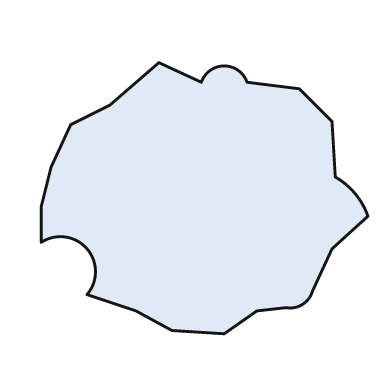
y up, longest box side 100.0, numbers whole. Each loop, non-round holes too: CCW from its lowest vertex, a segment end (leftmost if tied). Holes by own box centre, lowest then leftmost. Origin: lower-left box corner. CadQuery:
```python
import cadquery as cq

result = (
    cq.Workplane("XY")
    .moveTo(56.0, 0.0)
    .lineTo(66.0, 7.0)
    .lineTo(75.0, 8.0)
    .threePointArc((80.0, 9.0), (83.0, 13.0))
    .lineTo(89.0, 26.0)
    .lineTo(100.0, 36.0)
    .threePointArc((96.0, 43.0), (90.0, 48.0))
    .lineTo(89.0, 65.0)
    .lineTo(79.0, 75.0)
    .lineTo(63.0, 77.0)
    .threePointArc((56.0, 82.0), (49.0, 77.0))
    .lineTo(36.0, 83.0)
    .lineTo(21.0, 70.0)
    .lineTo(9.0, 64.0)
    .lineTo(3.0, 51.0)
    .lineTo(0.0, 39.0)
    .lineTo(0.0, 28.0)
    .threePointArc((14.0, 26.0), (14.0, 12.0))
    .lineTo(29.0, 7.0)
    .lineTo(40.0, 1.0)
    .close()
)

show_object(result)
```